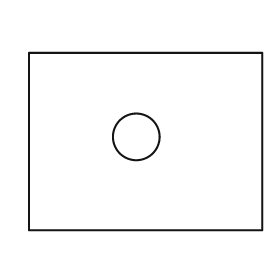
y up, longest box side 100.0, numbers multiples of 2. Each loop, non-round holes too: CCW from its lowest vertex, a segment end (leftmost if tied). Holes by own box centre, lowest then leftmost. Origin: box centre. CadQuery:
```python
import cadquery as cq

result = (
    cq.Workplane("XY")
    .moveTo(-50.0, -38.0)
    .lineTo(50.0, -38.0)
    .lineTo(50.0, 38.0)
    .lineTo(-50.0, 38.0)
    .close()
    .moveTo(-4.0, 2.0)
    .circle(10.0)
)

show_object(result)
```